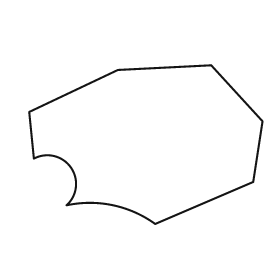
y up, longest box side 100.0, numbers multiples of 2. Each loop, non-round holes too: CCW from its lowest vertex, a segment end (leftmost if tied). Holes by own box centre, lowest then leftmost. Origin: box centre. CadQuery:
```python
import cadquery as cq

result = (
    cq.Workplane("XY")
    .moveTo(4.0, -34.0)
    .lineTo(46.0, -16.0)
    .lineTo(50.0, 10.0)
    .lineTo(28.0, 34.0)
    .lineTo(-12.0, 32.0)
    .lineTo(-50.0, 14.0)
    .lineTo(-48.0, -6.0)
    .threePointArc((-32.0, -10.0), (-34.0, -26.0))
    .threePointArc((-14.0, -26.0), (4.0, -34.0))
    .close()
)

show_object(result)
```